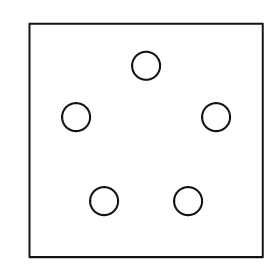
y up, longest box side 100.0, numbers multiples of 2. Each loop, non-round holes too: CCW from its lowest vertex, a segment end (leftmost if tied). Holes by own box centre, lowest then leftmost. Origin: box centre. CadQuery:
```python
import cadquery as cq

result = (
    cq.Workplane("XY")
    .moveTo(-50.0, -50.0)
    .lineTo(50.0, -50.0)
    .lineTo(50.0, 50.0)
    .lineTo(-50.0, 50.0)
    .close()
    .moveTo(-18.0, -26.0)
    .circle(6.0)
    .moveTo(18.0, -26.0)
    .circle(6.0)
    .moveTo(-30.0, 10.0)
    .circle(6.0)
    .moveTo(30.0, 10.0)
    .circle(6.0)
    .moveTo(0.0, 32.0)
    .circle(6.0)
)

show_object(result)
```